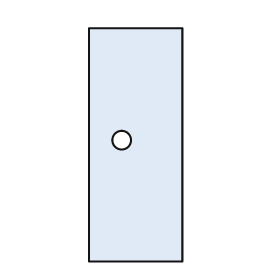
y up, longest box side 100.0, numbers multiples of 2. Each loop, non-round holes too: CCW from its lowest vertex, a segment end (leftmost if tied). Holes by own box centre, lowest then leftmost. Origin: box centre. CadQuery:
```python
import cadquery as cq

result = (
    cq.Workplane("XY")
    .moveTo(-20.0, -50.0)
    .lineTo(20.0, -50.0)
    .lineTo(20.0, 50.0)
    .lineTo(-20.0, 50.0)
    .close()
    .moveTo(-6.0, 2.0)
    .circle(4.0)
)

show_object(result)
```